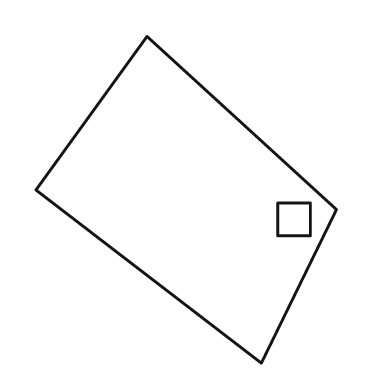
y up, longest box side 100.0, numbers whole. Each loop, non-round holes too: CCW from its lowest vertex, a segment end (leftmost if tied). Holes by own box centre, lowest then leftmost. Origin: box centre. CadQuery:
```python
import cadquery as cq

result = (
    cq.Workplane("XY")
    .moveTo(23.0, -50.0)
    .lineTo(46.0, -3.0)
    .lineTo(-12.0, 50.0)
    .lineTo(-46.0, 3.0)
    .close()
    .moveTo(28.0, -11.0)
    .lineTo(38.0, -11.0)
    .lineTo(38.0, -1.0)
    .lineTo(28.0, -1.0)
    .close()
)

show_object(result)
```